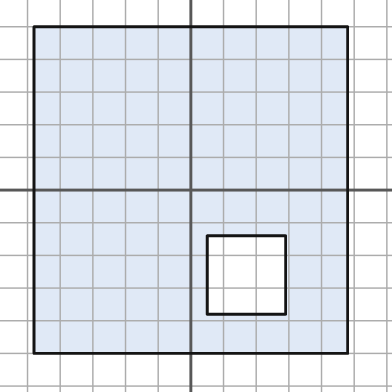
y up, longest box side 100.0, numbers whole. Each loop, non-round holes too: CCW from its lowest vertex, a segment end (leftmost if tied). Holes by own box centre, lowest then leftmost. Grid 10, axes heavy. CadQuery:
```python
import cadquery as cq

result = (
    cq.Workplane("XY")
    .moveTo(-48.0, -50.0)
    .lineTo(48.0, -50.0)
    .lineTo(48.0, 50.0)
    .lineTo(-48.0, 50.0)
    .close()
    .moveTo(5.0, -38.0)
    .lineTo(29.0, -38.0)
    .lineTo(29.0, -14.0)
    .lineTo(5.0, -14.0)
    .close()
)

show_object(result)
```